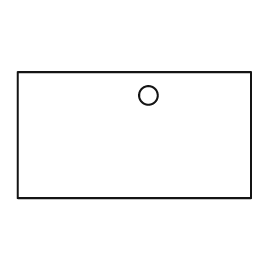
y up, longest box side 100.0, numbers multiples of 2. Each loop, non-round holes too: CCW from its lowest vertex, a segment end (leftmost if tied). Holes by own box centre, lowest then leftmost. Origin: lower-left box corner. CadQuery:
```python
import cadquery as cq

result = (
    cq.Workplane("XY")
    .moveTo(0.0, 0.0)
    .lineTo(100.0, 0.0)
    .lineTo(100.0, 54.0)
    .lineTo(0.0, 54.0)
    .close()
    .moveTo(56.0, 44.0)
    .circle(4.0)
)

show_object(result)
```